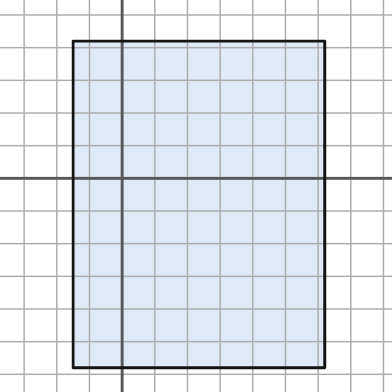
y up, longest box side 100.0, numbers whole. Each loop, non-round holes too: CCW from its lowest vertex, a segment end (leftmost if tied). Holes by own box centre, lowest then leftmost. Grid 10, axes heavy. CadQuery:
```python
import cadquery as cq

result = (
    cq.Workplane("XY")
    .moveTo(-15.0, -58.0)
    .lineTo(62.0, -58.0)
    .lineTo(62.0, 42.0)
    .lineTo(-15.0, 42.0)
    .close()
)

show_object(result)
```